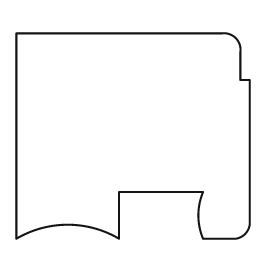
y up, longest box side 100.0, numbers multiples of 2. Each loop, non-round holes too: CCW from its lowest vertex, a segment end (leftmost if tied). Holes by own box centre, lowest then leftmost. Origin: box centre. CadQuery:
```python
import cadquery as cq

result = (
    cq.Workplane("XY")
    .moveTo(-50.0, -44.0)
    .threePointArc((-28.0, -38.0), (-6.0, -44.0))
    .lineTo(-6.0, -24.0)
    .lineTo(30.0, -24.0)
    .threePointArc((28.0, -34.0), (30.0, -44.0))
    .lineTo(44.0, -44.0)
    .threePointArc((48.0, -42.0), (50.0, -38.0))
    .lineTo(50.0, 24.0)
    .lineTo(46.0, 24.0)
    .lineTo(46.0, 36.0)
    .threePointArc((44.0, 42.0), (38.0, 44.0))
    .lineTo(-50.0, 44.0)
    .close()
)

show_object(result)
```